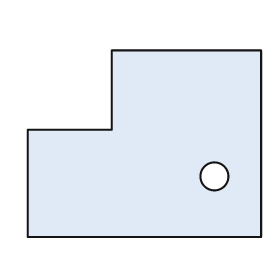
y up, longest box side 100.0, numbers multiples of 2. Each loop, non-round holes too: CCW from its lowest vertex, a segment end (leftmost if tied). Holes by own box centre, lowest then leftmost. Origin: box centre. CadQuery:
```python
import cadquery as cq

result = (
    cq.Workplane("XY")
    .moveTo(-50.0, -40.0)
    .lineTo(50.0, -40.0)
    .lineTo(50.0, 40.0)
    .lineTo(-14.0, 40.0)
    .lineTo(-14.0, 6.0)
    .lineTo(-50.0, 6.0)
    .close()
    .moveTo(30.0, -14.0)
    .circle(6.0)
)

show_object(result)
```